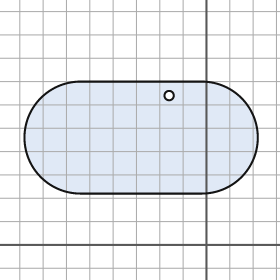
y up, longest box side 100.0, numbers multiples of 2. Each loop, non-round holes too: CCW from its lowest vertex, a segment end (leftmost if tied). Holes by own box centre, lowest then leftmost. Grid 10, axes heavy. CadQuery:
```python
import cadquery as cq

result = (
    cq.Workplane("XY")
    .moveTo(-54.0, 22.0)
    .lineTo(-2.0, 22.0)
    .threePointArc((22.0, 46.0), (-2.0, 70.0))
    .lineTo(-54.0, 70.0)
    .threePointArc((-78.0, 46.0), (-54.0, 22.0))
    .close()
    .moveTo(-16.0, 64.0)
    .circle(2.0)
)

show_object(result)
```